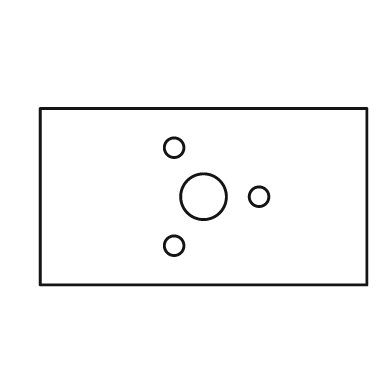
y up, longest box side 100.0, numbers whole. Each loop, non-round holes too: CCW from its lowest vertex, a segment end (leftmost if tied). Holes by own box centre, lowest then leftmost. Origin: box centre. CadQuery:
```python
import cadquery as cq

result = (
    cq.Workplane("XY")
    .moveTo(-50.0, -27.0)
    .lineTo(50.0, -27.0)
    .lineTo(50.0, 27.0)
    .lineTo(-50.0, 27.0)
    .close()
    .moveTo(-9.0, -15.0)
    .circle(3.0)
    .moveTo(0.0, 0.0)
    .circle(7.0)
    .moveTo(17.0, 0.0)
    .circle(3.0)
    .moveTo(-9.0, 15.0)
    .circle(3.0)
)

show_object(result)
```